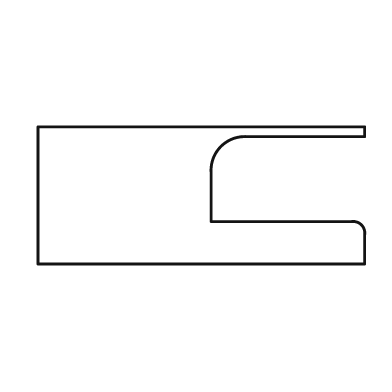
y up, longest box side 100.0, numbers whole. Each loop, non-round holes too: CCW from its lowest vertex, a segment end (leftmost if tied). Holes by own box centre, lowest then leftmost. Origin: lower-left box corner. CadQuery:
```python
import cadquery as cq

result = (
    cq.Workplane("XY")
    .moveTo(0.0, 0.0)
    .lineTo(100.0, 0.0)
    .lineTo(100.0, 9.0)
    .threePointArc((99.0, 12.0), (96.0, 13.0))
    .lineTo(53.0, 13.0)
    .lineTo(53.0, 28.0)
    .threePointArc((56.0, 36.0), (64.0, 39.0))
    .lineTo(100.0, 39.0)
    .lineTo(100.0, 42.0)
    .lineTo(0.0, 42.0)
    .close()
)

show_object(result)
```